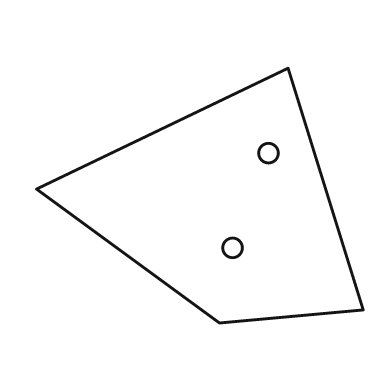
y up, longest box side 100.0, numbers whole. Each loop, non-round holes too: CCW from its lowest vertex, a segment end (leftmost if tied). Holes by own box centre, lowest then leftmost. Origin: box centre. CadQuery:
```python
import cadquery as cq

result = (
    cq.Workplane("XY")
    .moveTo(6.0, -39.0)
    .lineTo(50.0, -35.0)
    .lineTo(27.0, 39.0)
    .lineTo(-50.0, 2.0)
    .close()
    .moveTo(10.0, -16.0)
    .circle(3.0)
    .moveTo(21.0, 13.0)
    .circle(3.0)
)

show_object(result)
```